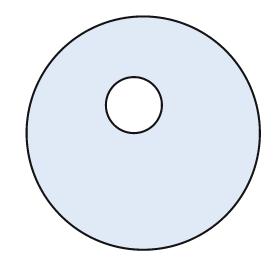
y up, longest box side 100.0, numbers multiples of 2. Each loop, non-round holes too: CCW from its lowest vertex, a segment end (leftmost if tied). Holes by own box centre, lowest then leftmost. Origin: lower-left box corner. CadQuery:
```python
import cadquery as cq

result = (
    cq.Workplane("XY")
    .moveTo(50.0, 50.0)
    .circle(50.0)
    .moveTo(46.0, 62.0)
    .circle(12.0)
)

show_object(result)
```